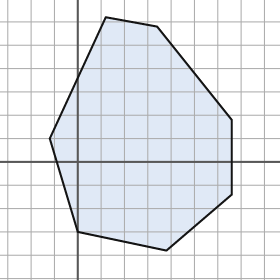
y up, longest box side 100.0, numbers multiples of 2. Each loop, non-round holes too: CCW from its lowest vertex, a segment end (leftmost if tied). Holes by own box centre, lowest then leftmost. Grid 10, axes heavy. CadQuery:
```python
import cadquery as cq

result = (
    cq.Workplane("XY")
    .moveTo(38.0, -38.0)
    .lineTo(66.0, -14.0)
    .lineTo(66.0, 18.0)
    .lineTo(34.0, 58.0)
    .lineTo(12.0, 62.0)
    .lineTo(-12.0, 10.0)
    .lineTo(0.0, -30.0)
    .close()
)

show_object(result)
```